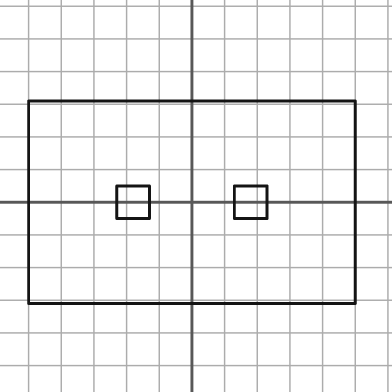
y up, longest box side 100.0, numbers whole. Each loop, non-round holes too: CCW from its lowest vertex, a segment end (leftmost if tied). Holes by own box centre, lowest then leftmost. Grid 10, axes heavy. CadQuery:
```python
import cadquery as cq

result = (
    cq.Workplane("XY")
    .moveTo(-50.0, -31.0)
    .lineTo(50.0, -31.0)
    .lineTo(50.0, 31.0)
    .lineTo(-50.0, 31.0)
    .close()
    .moveTo(-23.0, -5.0)
    .lineTo(-13.0, -5.0)
    .lineTo(-13.0, 5.0)
    .lineTo(-23.0, 5.0)
    .close()
    .moveTo(13.0, -5.0)
    .lineTo(23.0, -5.0)
    .lineTo(23.0, 5.0)
    .lineTo(13.0, 5.0)
    .close()
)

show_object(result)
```